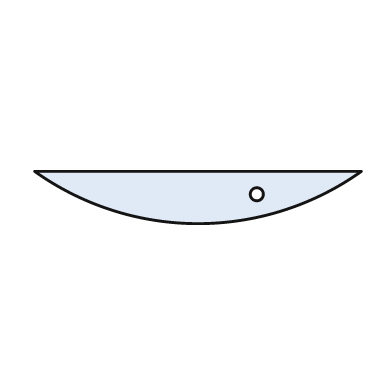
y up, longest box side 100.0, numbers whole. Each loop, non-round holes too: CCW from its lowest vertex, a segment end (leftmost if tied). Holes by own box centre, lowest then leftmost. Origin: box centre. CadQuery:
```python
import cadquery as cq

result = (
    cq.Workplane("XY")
    .moveTo(-50.0, 8.0)
    .threePointArc((0.0, -8.0), (50.0, 8.0))
    .close()
    .moveTo(18.0, 1.0)
    .circle(2.0)
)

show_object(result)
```